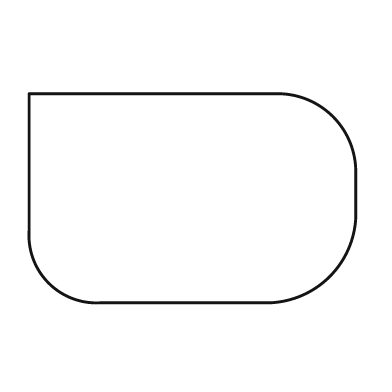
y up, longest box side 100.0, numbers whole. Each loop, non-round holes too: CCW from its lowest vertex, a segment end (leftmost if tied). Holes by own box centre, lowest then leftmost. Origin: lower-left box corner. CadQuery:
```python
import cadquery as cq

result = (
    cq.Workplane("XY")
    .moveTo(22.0, 0.0)
    .lineTo(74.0, 0.0)
    .threePointArc((92.0, 8.0), (100.0, 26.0))
    .lineTo(100.0, 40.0)
    .threePointArc((93.0, 57.0), (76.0, 64.0))
    .lineTo(0.0, 64.0)
    .lineTo(0.0, 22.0)
    .threePointArc((6.0, 6.0), (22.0, 0.0))
    .close()
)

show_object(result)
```